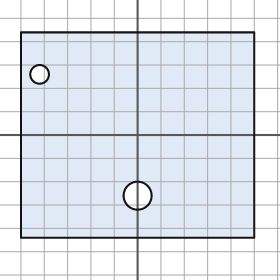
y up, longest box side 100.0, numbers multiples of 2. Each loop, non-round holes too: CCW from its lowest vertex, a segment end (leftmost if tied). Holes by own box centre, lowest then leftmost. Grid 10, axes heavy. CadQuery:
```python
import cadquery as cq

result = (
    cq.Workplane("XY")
    .moveTo(-50.0, -44.0)
    .lineTo(50.0, -44.0)
    .lineTo(50.0, 44.0)
    .lineTo(-50.0, 44.0)
    .close()
    .moveTo(0.0, -26.0)
    .circle(6.0)
    .moveTo(-42.0, 26.0)
    .circle(4.0)
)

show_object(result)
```